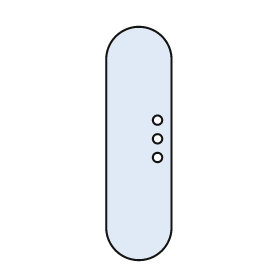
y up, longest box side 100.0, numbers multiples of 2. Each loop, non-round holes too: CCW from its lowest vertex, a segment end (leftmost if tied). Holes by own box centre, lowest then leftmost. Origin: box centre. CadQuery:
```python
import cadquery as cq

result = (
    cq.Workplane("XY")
    .moveTo(-14.0, -36.0)
    .threePointArc((0.0, -50.0), (14.0, -36.0))
    .lineTo(14.0, 36.0)
    .threePointArc((0.0, 50.0), (-14.0, 36.0))
    .close()
    .moveTo(8.0, -6.0)
    .circle(2.0)
    .moveTo(8.0, 2.0)
    .circle(2.0)
    .moveTo(8.0, 10.0)
    .circle(2.0)
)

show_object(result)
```